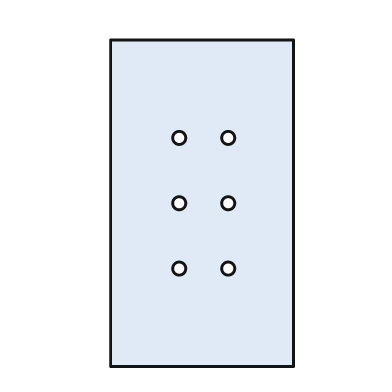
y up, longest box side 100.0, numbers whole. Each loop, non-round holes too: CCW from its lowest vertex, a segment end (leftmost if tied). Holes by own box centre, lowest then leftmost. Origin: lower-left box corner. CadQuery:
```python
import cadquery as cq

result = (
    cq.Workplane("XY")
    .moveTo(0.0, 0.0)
    .lineTo(56.0, 0.0)
    .lineTo(56.0, 100.0)
    .lineTo(0.0, 100.0)
    .close()
    .moveTo(21.0, 30.0)
    .circle(2.0)
    .moveTo(36.0, 30.0)
    .circle(2.0)
    .moveTo(21.0, 50.0)
    .circle(2.0)
    .moveTo(36.0, 50.0)
    .circle(2.0)
    .moveTo(21.0, 70.0)
    .circle(2.0)
    .moveTo(36.0, 70.0)
    .circle(2.0)
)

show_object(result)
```